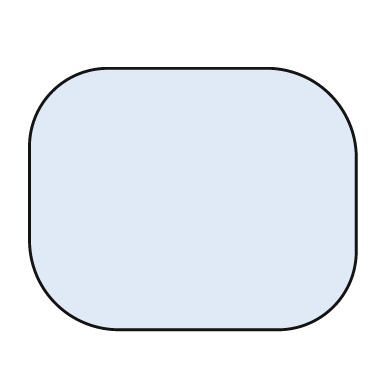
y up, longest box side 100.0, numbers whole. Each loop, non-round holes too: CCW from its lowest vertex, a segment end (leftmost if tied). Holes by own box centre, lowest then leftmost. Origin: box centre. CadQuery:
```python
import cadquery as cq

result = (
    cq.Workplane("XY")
    .moveTo(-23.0, -40.0)
    .lineTo(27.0, -40.0)
    .threePointArc((43.0, -33.0), (50.0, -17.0))
    .lineTo(50.0, 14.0)
    .threePointArc((42.0, 32.0), (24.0, 40.0))
    .lineTo(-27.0, 40.0)
    .threePointArc((-43.0, 33.0), (-50.0, 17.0))
    .lineTo(-50.0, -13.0)
    .threePointArc((-42.0, -32.0), (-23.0, -40.0))
    .close()
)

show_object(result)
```